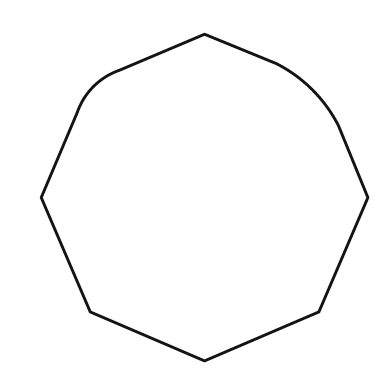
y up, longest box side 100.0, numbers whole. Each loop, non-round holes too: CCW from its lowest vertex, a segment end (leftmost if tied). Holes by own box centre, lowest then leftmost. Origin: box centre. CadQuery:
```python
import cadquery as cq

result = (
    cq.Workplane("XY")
    .moveTo(0.0, -50.0)
    .lineTo(35.0, -35.0)
    .lineTo(50.0, 0.0)
    .lineTo(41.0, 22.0)
    .threePointArc((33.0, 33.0), (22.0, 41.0))
    .lineTo(0.0, 50.0)
    .lineTo(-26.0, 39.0)
    .threePointArc((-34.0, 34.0), (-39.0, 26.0))
    .lineTo(-50.0, 0.0)
    .lineTo(-35.0, -35.0)
    .close()
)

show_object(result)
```